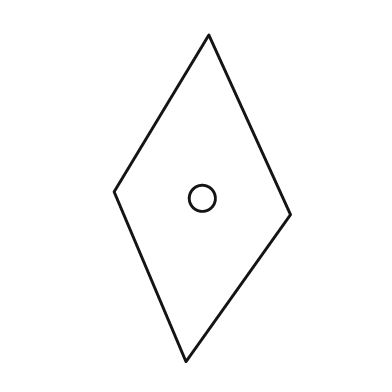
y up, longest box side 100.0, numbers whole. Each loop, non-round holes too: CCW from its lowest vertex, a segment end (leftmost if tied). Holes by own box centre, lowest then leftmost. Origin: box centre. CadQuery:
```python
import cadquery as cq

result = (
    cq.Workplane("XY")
    .moveTo(-5.0, -50.0)
    .lineTo(27.0, -5.0)
    .lineTo(2.0, 50.0)
    .lineTo(-27.0, 2.0)
    .close()
    .moveTo(0.0, 0.0)
    .circle(4.0)
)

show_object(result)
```